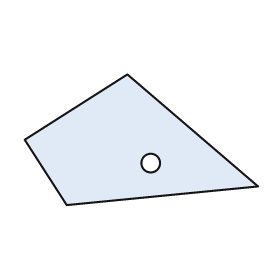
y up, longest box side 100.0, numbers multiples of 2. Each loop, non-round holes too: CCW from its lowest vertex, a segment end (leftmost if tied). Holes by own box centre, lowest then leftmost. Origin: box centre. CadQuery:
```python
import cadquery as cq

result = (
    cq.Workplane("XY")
    .moveTo(-32.0, -28.0)
    .lineTo(50.0, -20.0)
    .lineTo(-6.0, 28.0)
    .lineTo(-50.0, 0.0)
    .close()
    .moveTo(4.0, -10.0)
    .circle(4.0)
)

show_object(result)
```